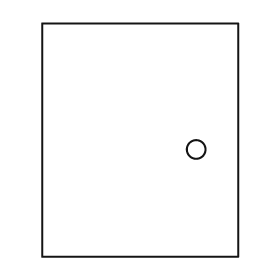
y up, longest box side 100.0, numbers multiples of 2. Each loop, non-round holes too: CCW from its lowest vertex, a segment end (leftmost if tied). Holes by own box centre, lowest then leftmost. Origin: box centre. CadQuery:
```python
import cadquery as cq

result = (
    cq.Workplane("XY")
    .moveTo(-42.0, -50.0)
    .lineTo(42.0, -50.0)
    .lineTo(42.0, 50.0)
    .lineTo(-42.0, 50.0)
    .close()
    .moveTo(24.0, -4.0)
    .circle(4.0)
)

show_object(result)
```